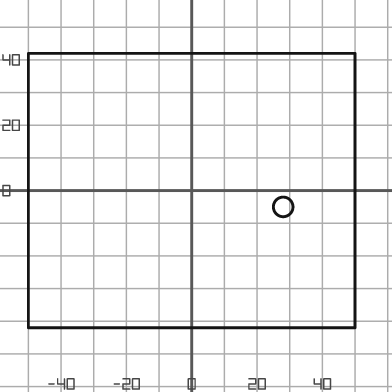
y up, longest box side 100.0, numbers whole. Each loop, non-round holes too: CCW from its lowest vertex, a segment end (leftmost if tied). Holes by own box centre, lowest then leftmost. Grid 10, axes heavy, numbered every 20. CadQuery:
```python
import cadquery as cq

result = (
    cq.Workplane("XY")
    .moveTo(-50.0, -42.0)
    .lineTo(50.0, -42.0)
    .lineTo(50.0, 42.0)
    .lineTo(-50.0, 42.0)
    .close()
    .moveTo(28.0, -5.0)
    .circle(3.0)
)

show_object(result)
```